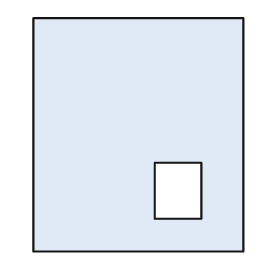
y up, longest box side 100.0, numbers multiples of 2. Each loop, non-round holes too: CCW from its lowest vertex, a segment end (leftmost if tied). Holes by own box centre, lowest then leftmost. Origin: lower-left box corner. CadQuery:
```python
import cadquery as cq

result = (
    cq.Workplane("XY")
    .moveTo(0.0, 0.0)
    .lineTo(90.0, 0.0)
    .lineTo(90.0, 100.0)
    .lineTo(0.0, 100.0)
    .close()
    .moveTo(52.0, 14.0)
    .lineTo(72.0, 14.0)
    .lineTo(72.0, 38.0)
    .lineTo(52.0, 38.0)
    .close()
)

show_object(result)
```